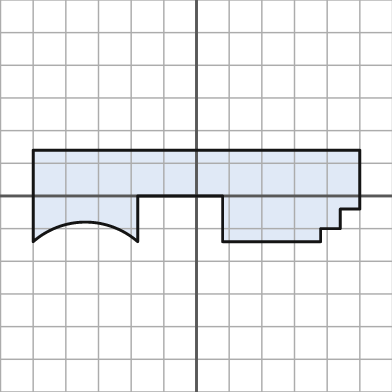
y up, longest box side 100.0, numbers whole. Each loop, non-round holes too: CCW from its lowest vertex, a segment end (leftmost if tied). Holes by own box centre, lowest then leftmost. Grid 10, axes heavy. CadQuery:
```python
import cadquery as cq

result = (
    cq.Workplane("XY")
    .moveTo(-50.0, -14.0)
    .threePointArc((-34.0, -8.0), (-18.0, -14.0))
    .lineTo(-18.0, 0.0)
    .lineTo(8.0, 0.0)
    .lineTo(8.0, -14.0)
    .lineTo(38.0, -14.0)
    .lineTo(38.0, -10.0)
    .lineTo(44.0, -10.0)
    .lineTo(44.0, -4.0)
    .lineTo(50.0, -4.0)
    .lineTo(50.0, 14.0)
    .lineTo(-50.0, 14.0)
    .close()
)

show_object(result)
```